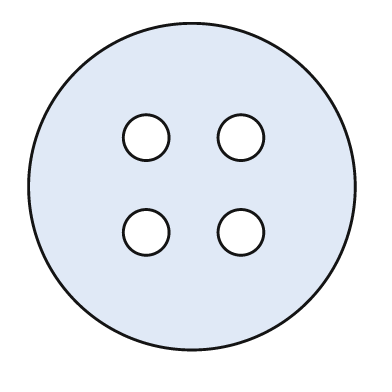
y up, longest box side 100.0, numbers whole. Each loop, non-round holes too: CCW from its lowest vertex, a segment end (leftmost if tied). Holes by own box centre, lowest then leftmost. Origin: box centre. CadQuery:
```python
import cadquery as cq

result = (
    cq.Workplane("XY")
    .moveTo(0.0, 0.0)
    .circle(50.0)
    .moveTo(-14.0, -14.0)
    .circle(7.0)
    .moveTo(15.0, -14.0)
    .circle(7.0)
    .moveTo(-14.0, 15.0)
    .circle(7.0)
    .moveTo(15.0, 15.0)
    .circle(7.0)
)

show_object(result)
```